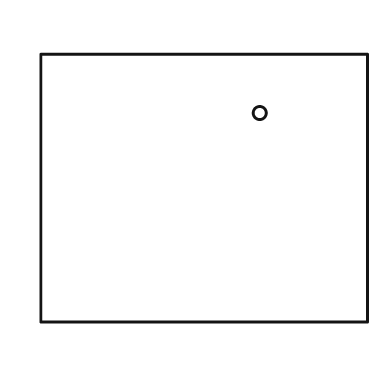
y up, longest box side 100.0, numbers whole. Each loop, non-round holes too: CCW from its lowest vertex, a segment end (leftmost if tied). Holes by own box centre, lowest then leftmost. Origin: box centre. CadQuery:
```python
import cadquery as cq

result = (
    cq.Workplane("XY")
    .moveTo(-50.0, -41.0)
    .lineTo(50.0, -41.0)
    .lineTo(50.0, 41.0)
    .lineTo(-50.0, 41.0)
    .close()
    .moveTo(17.0, 23.0)
    .circle(2.0)
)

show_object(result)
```